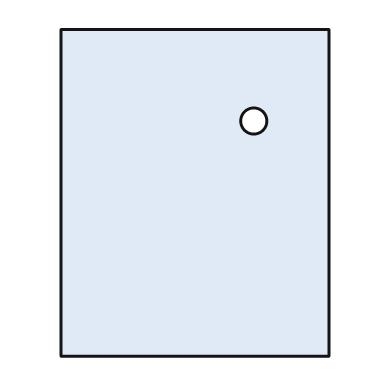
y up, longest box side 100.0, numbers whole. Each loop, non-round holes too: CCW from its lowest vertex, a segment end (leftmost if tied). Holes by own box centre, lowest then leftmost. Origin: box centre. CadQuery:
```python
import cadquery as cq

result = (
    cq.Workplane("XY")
    .moveTo(-41.0, -50.0)
    .lineTo(41.0, -50.0)
    .lineTo(41.0, 50.0)
    .lineTo(-41.0, 50.0)
    .close()
    .moveTo(18.0, 22.0)
    .circle(4.0)
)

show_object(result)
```